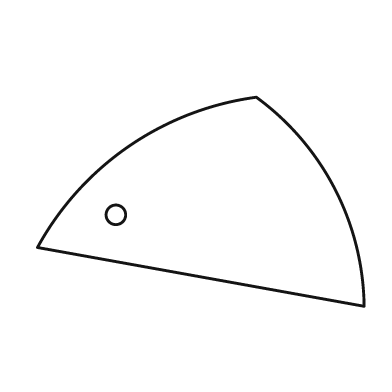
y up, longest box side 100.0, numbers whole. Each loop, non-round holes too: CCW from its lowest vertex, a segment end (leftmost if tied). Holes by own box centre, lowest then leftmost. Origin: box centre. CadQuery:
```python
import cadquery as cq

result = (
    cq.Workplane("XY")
    .moveTo(50.0, -32.0)
    .threePointArc((41.0, 4.0), (17.0, 32.0))
    .threePointArc((-22.0, 17.0), (-50.0, -14.0))
    .close()
    .moveTo(-26.0, -4.0)
    .circle(3.0)
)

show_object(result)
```